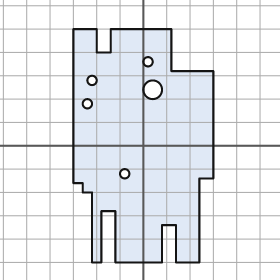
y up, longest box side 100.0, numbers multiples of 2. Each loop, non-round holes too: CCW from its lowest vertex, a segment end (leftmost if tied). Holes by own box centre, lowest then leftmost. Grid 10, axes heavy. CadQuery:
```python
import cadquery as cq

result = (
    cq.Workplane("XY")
    .moveTo(-22.0, -50.0)
    .lineTo(-18.0, -50.0)
    .lineTo(-18.0, -28.0)
    .lineTo(-12.0, -28.0)
    .lineTo(-12.0, -50.0)
    .lineTo(8.0, -50.0)
    .lineTo(8.0, -34.0)
    .lineTo(14.0, -34.0)
    .lineTo(14.0, -50.0)
    .lineTo(24.0, -50.0)
    .lineTo(24.0, -14.0)
    .lineTo(30.0, -14.0)
    .lineTo(30.0, 32.0)
    .lineTo(12.0, 32.0)
    .lineTo(12.0, 50.0)
    .lineTo(-14.0, 50.0)
    .lineTo(-14.0, 40.0)
    .lineTo(-20.0, 40.0)
    .lineTo(-20.0, 50.0)
    .lineTo(-30.0, 50.0)
    .lineTo(-30.0, -16.0)
    .lineTo(-26.0, -16.0)
    .lineTo(-26.0, -20.0)
    .lineTo(-22.0, -20.0)
    .close()
    .moveTo(-8.0, -12.0)
    .circle(2.0)
    .moveTo(-24.0, 18.0)
    .circle(2.0)
    .moveTo(4.0, 24.0)
    .circle(4.0)
    .moveTo(-22.0, 28.0)
    .circle(2.0)
    .moveTo(2.0, 36.0)
    .circle(2.0)
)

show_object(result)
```